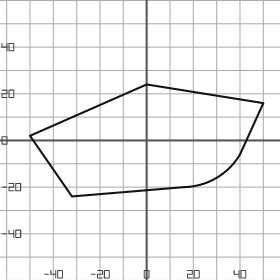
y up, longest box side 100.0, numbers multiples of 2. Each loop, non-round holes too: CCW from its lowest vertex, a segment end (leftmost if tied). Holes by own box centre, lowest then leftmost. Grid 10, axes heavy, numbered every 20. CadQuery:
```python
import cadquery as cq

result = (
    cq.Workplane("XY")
    .moveTo(-32.0, -24.0)
    .lineTo(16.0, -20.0)
    .threePointArc((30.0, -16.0), (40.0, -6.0))
    .lineTo(50.0, 16.0)
    .lineTo(0.0, 24.0)
    .lineTo(-50.0, 2.0)
    .close()
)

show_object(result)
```